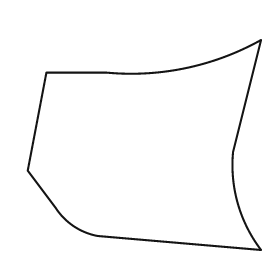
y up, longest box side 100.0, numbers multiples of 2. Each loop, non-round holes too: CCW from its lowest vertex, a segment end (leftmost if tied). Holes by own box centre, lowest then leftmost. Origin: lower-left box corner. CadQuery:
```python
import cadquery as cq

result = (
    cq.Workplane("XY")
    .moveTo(100.0, 0.0)
    .threePointArc((90.0, 20.0), (88.0, 42.0))
    .lineTo(100.0, 90.0)
    .threePointArc((68.0, 78.0), (34.0, 76.0))
    .lineTo(8.0, 76.0)
    .lineTo(0.0, 34.0)
    .lineTo(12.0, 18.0)
    .threePointArc((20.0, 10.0), (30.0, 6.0))
    .close()
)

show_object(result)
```